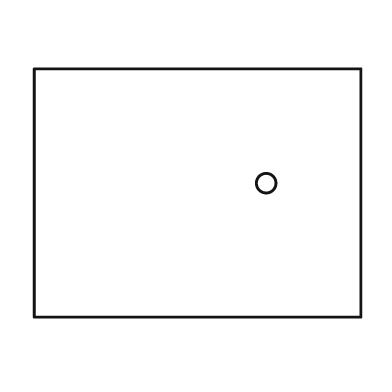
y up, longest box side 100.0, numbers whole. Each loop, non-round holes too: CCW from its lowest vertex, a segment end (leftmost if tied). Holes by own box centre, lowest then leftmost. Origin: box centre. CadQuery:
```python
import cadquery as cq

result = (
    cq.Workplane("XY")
    .moveTo(-50.0, -38.0)
    .lineTo(50.0, -38.0)
    .lineTo(50.0, 38.0)
    .lineTo(-50.0, 38.0)
    .close()
    .moveTo(21.0, 3.0)
    .circle(3.0)
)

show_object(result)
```